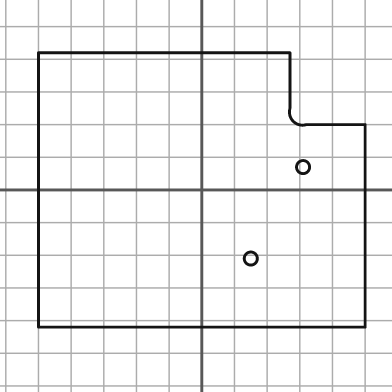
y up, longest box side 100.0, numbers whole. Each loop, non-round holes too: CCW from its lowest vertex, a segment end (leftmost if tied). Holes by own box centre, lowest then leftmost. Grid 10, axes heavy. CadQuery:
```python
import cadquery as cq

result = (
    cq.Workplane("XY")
    .moveTo(-50.0, -42.0)
    .lineTo(50.0, -42.0)
    .lineTo(50.0, 20.0)
    .lineTo(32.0, 20.0)
    .threePointArc((28.0, 21.0), (27.0, 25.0))
    .lineTo(27.0, 42.0)
    .lineTo(-50.0, 42.0)
    .close()
    .moveTo(15.0, -21.0)
    .circle(2.0)
    .moveTo(31.0, 7.0)
    .circle(2.0)
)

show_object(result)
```